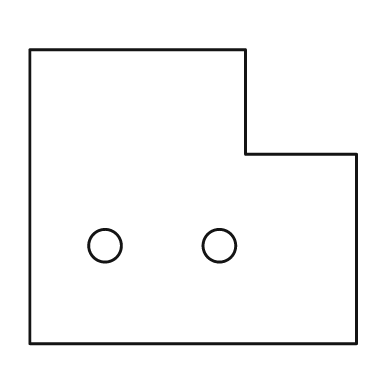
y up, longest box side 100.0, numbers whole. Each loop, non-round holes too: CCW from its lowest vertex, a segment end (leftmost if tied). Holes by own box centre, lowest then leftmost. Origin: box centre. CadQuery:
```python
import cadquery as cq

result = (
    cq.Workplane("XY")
    .moveTo(-50.0, -45.0)
    .lineTo(50.0, -45.0)
    .lineTo(50.0, 13.0)
    .lineTo(16.0, 13.0)
    .lineTo(16.0, 45.0)
    .lineTo(-50.0, 45.0)
    .close()
    .moveTo(-27.0, -15.0)
    .circle(5.0)
    .moveTo(8.0, -15.0)
    .circle(5.0)
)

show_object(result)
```